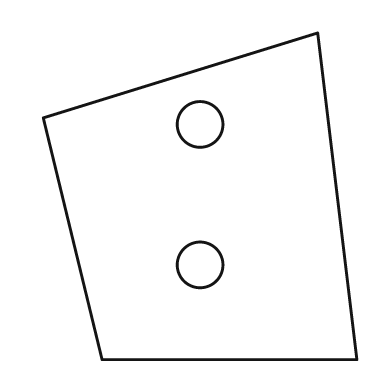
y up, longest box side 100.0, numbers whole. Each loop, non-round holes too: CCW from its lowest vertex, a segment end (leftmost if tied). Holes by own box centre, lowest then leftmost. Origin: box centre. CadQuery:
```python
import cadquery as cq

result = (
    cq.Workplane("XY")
    .moveTo(-30.0, -50.0)
    .lineTo(48.0, -50.0)
    .lineTo(36.0, 50.0)
    .lineTo(-48.0, 24.0)
    .close()
    .moveTo(0.0, -21.0)
    .circle(7.0)
    .moveTo(0.0, 22.0)
    .circle(7.0)
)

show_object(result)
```